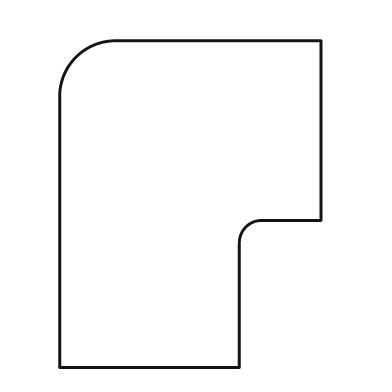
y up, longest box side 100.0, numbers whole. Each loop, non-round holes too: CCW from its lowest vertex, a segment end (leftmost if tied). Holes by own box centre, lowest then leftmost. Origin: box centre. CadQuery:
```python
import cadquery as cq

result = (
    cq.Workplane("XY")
    .moveTo(-40.0, -50.0)
    .lineTo(15.0, -50.0)
    .lineTo(15.0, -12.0)
    .threePointArc((17.0, -7.0), (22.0, -5.0))
    .lineTo(40.0, -5.0)
    .lineTo(40.0, 50.0)
    .lineTo(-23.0, 50.0)
    .threePointArc((-35.0, 45.0), (-40.0, 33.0))
    .close()
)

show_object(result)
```